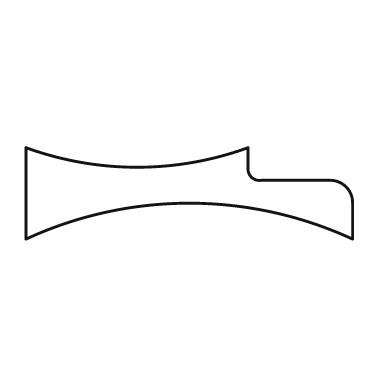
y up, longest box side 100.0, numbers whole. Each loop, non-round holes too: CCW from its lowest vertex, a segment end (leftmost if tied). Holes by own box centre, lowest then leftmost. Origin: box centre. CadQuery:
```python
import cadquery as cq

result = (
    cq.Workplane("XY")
    .moveTo(-50.0, -14.0)
    .threePointArc((0.0, -3.0), (50.0, -14.0))
    .lineTo(50.0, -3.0)
    .threePointArc((48.0, 2.0), (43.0, 4.0))
    .lineTo(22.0, 4.0)
    .threePointArc((19.0, 5.0), (18.0, 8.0))
    .lineTo(18.0, 14.0)
    .threePointArc((-16.0, 8.0), (-50.0, 14.0))
    .close()
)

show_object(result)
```